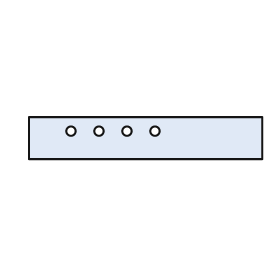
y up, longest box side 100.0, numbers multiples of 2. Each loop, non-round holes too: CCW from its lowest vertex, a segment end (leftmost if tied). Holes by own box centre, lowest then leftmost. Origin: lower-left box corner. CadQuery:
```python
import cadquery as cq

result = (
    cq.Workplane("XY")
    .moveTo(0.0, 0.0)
    .lineTo(100.0, 0.0)
    .lineTo(100.0, 18.0)
    .lineTo(0.0, 18.0)
    .close()
    .moveTo(18.0, 12.0)
    .circle(2.0)
    .moveTo(30.0, 12.0)
    .circle(2.0)
    .moveTo(42.0, 12.0)
    .circle(2.0)
    .moveTo(54.0, 12.0)
    .circle(2.0)
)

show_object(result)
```